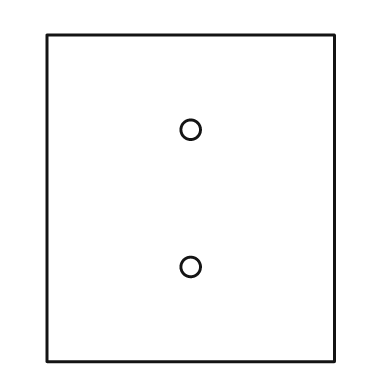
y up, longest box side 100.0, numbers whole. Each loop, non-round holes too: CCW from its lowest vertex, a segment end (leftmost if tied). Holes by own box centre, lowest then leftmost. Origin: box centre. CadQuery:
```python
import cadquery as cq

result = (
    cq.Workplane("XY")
    .moveTo(-44.0, -50.0)
    .lineTo(44.0, -50.0)
    .lineTo(44.0, 50.0)
    .lineTo(-44.0, 50.0)
    .close()
    .moveTo(0.0, -21.0)
    .circle(3.0)
    .moveTo(0.0, 21.0)
    .circle(3.0)
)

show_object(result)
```